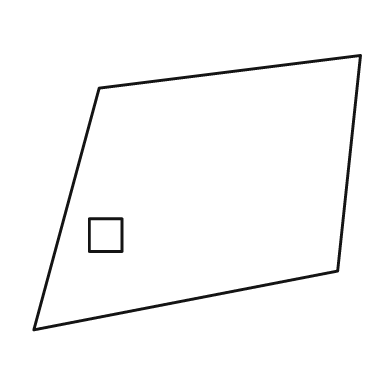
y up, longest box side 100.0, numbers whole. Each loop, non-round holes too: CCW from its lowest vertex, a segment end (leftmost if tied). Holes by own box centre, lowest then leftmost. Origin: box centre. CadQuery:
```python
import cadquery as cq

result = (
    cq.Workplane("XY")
    .moveTo(-50.0, -42.0)
    .lineTo(43.0, -24.0)
    .lineTo(50.0, 42.0)
    .lineTo(-30.0, 32.0)
    .close()
    .moveTo(-33.0, -18.0)
    .lineTo(-23.0, -18.0)
    .lineTo(-23.0, -8.0)
    .lineTo(-33.0, -8.0)
    .close()
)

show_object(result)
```